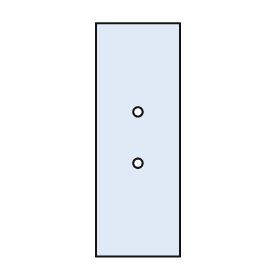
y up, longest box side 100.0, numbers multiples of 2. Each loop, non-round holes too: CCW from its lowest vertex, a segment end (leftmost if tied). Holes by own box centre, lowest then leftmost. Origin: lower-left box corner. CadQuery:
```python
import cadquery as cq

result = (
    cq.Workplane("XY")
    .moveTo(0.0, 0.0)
    .lineTo(36.0, 0.0)
    .lineTo(36.0, 100.0)
    .lineTo(0.0, 100.0)
    .close()
    .moveTo(18.0, 40.0)
    .circle(2.0)
    .moveTo(18.0, 62.0)
    .circle(2.0)
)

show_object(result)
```